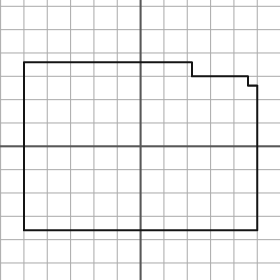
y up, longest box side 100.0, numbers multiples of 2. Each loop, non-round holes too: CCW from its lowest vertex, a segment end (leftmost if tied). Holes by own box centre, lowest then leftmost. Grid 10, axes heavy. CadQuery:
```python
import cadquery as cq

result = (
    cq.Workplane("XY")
    .moveTo(-50.0, -36.0)
    .lineTo(50.0, -36.0)
    .lineTo(50.0, 26.0)
    .lineTo(46.0, 26.0)
    .lineTo(46.0, 30.0)
    .lineTo(22.0, 30.0)
    .lineTo(22.0, 36.0)
    .lineTo(-50.0, 36.0)
    .close()
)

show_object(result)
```